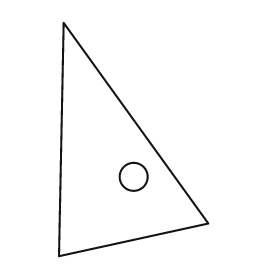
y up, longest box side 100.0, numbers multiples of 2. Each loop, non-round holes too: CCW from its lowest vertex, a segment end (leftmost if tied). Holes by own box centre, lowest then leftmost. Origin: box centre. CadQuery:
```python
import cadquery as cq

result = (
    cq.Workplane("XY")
    .moveTo(-32.0, -50.0)
    .lineTo(32.0, -36.0)
    .lineTo(-30.0, 50.0)
    .close()
    .moveTo(0.0, -16.0)
    .circle(6.0)
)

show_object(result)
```